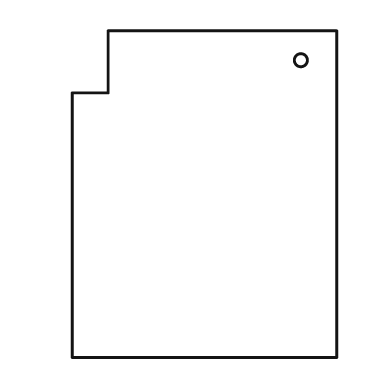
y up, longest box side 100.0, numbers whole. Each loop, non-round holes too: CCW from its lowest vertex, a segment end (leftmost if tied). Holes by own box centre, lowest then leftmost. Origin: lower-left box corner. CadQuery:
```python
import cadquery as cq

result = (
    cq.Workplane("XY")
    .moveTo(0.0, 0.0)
    .lineTo(81.0, 0.0)
    .lineTo(81.0, 100.0)
    .lineTo(11.0, 100.0)
    .lineTo(11.0, 81.0)
    .lineTo(0.0, 81.0)
    .close()
    .moveTo(70.0, 91.0)
    .circle(2.0)
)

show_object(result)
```